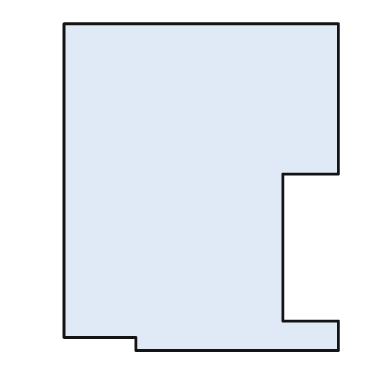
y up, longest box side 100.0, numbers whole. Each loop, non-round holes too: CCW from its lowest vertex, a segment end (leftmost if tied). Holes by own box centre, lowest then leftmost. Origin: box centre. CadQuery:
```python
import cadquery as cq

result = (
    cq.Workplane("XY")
    .moveTo(-20.0, -50.0)
    .lineTo(42.0, -50.0)
    .lineTo(42.0, -41.0)
    .lineTo(25.0, -41.0)
    .lineTo(25.0, 4.0)
    .lineTo(42.0, 4.0)
    .lineTo(42.0, 50.0)
    .lineTo(-42.0, 50.0)
    .lineTo(-42.0, -46.0)
    .lineTo(-20.0, -46.0)
    .close()
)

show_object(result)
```